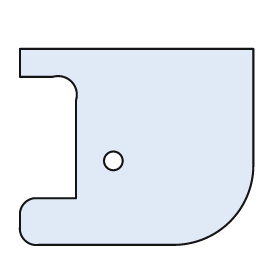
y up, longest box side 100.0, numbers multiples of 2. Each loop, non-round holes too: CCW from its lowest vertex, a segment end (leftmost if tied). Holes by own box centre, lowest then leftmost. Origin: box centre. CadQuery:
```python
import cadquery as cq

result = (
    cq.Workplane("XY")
    .moveTo(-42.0, -42.0)
    .lineTo(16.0, -42.0)
    .threePointArc((40.0, -32.0), (50.0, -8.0))
    .lineTo(50.0, 42.0)
    .lineTo(-50.0, 42.0)
    .lineTo(-50.0, 30.0)
    .lineTo(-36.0, 30.0)
    .threePointArc((-28.0, 28.0), (-26.0, 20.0))
    .lineTo(-26.0, -22.0)
    .lineTo(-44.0, -22.0)
    .threePointArc((-48.0, -24.0), (-50.0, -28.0))
    .lineTo(-50.0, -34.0)
    .threePointArc((-48.0, -40.0), (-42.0, -42.0))
    .close()
    .moveTo(-10.0, -6.0)
    .circle(4.0)
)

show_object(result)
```